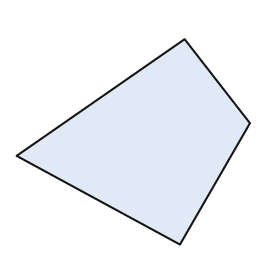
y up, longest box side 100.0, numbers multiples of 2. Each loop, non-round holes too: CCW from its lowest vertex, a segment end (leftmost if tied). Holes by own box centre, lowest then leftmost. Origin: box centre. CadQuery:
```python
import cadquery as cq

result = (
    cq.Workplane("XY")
    .moveTo(20.0, -44.0)
    .lineTo(50.0, 8.0)
    .lineTo(22.0, 44.0)
    .lineTo(-50.0, -6.0)
    .close()
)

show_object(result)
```